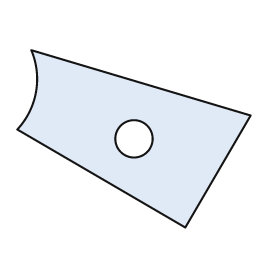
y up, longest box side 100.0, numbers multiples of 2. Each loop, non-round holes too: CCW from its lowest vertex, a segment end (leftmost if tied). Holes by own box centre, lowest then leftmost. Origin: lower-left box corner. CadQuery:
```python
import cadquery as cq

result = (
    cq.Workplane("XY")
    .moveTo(72.0, 0.0)
    .lineTo(100.0, 48.0)
    .lineTo(6.0, 76.0)
    .threePointArc((8.0, 58.0), (0.0, 42.0))
    .close()
    .moveTo(50.0, 38.0)
    .circle(8.0)
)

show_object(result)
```